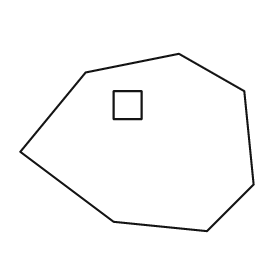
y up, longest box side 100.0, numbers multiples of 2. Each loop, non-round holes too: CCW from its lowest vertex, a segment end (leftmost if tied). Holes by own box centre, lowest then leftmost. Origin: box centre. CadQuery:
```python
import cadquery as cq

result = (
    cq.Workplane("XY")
    .moveTo(30.0, -38.0)
    .lineTo(50.0, -18.0)
    .lineTo(46.0, 22.0)
    .lineTo(18.0, 38.0)
    .lineTo(-22.0, 30.0)
    .lineTo(-50.0, -4.0)
    .lineTo(-10.0, -34.0)
    .close()
    .moveTo(-10.0, 10.0)
    .lineTo(2.0, 10.0)
    .lineTo(2.0, 22.0)
    .lineTo(-10.0, 22.0)
    .close()
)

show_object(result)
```